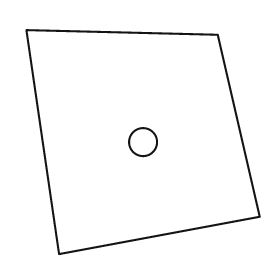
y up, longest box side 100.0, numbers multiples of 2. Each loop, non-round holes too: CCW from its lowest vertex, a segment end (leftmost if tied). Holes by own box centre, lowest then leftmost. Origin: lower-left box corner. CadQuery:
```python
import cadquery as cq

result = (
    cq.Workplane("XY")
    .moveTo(14.0, 0.0)
    .lineTo(100.0, 16.0)
    .lineTo(82.0, 94.0)
    .lineTo(0.0, 96.0)
    .close()
    .moveTo(50.0, 48.0)
    .circle(6.0)
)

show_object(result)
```